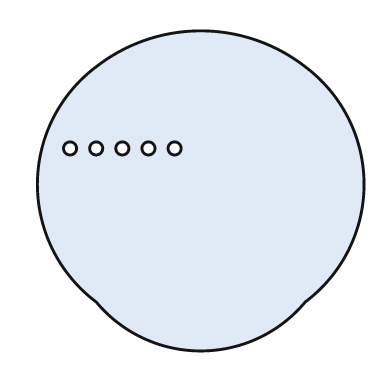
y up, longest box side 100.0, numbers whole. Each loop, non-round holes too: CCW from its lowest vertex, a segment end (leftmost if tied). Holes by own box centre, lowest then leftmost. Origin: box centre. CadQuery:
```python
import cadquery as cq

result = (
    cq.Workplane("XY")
    .moveTo(-32.0, -34.0)
    .threePointArc((0.0, -49.0), (32.0, -34.0))
    .threePointArc((50.0, 2.0), (32.0, 38.0))
    .threePointArc((0.0, 49.0), (-32.0, 38.0))
    .threePointArc((-50.0, 2.0), (-32.0, -34.0))
    .close()
    .moveTo(-40.0, 13.0)
    .circle(2.0)
    .moveTo(-32.0, 13.0)
    .circle(2.0)
    .moveTo(-24.0, 13.0)
    .circle(2.0)
    .moveTo(-16.0, 13.0)
    .circle(2.0)
    .moveTo(-8.0, 13.0)
    .circle(2.0)
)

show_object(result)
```